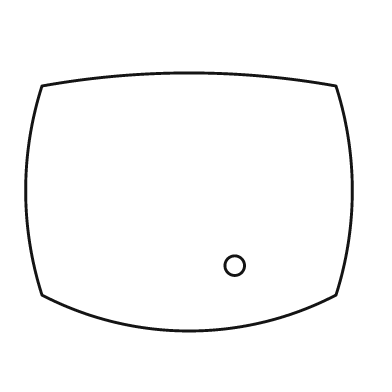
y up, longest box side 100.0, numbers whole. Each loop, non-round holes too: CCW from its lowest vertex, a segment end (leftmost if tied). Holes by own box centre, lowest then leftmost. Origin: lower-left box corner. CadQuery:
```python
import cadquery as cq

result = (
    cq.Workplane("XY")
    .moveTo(5.0, 11.0)
    .threePointArc((50.0, 0.0), (95.0, 11.0))
    .threePointArc((100.0, 43.0), (95.0, 75.0))
    .threePointArc((50.0, 79.0), (5.0, 75.0))
    .threePointArc((0.0, 43.0), (5.0, 11.0))
    .close()
    .moveTo(64.0, 20.0)
    .circle(3.0)
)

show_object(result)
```